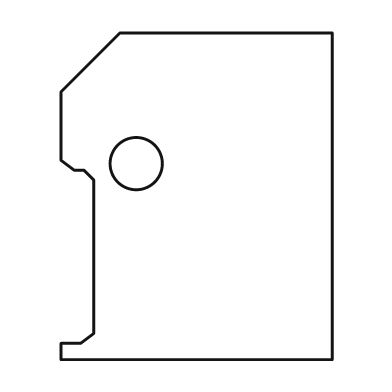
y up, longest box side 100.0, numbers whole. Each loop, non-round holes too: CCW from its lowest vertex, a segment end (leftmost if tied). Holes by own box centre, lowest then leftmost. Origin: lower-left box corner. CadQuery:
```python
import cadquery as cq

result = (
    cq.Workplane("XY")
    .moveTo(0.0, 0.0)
    .lineTo(83.0, 0.0)
    .lineTo(83.0, 100.0)
    .lineTo(18.0, 100.0)
    .lineTo(0.0, 82.0)
    .lineTo(0.0, 61.0)
    .lineTo(4.0, 58.0)
    .lineTo(7.0, 58.0)
    .lineTo(10.0, 55.0)
    .lineTo(10.0, 8.0)
    .lineTo(6.0, 5.0)
    .lineTo(0.0, 5.0)
    .close()
    .moveTo(23.0, 60.0)
    .circle(8.0)
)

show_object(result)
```